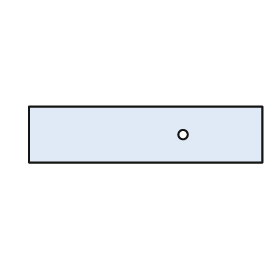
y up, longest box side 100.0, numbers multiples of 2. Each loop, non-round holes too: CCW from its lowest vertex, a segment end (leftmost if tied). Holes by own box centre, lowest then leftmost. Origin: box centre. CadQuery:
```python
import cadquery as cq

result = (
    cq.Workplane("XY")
    .moveTo(-50.0, -12.0)
    .lineTo(50.0, -12.0)
    .lineTo(50.0, 12.0)
    .lineTo(-50.0, 12.0)
    .close()
    .moveTo(16.0, 0.0)
    .circle(2.0)
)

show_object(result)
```